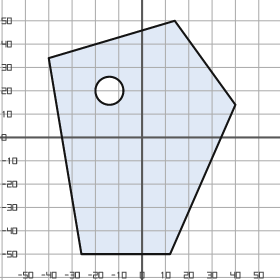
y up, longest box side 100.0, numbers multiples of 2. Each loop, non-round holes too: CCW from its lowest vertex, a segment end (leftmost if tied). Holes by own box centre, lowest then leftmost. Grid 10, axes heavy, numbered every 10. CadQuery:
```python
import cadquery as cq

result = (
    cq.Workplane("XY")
    .moveTo(-26.0, -50.0)
    .lineTo(12.0, -50.0)
    .lineTo(40.0, 14.0)
    .lineTo(14.0, 50.0)
    .lineTo(-40.0, 34.0)
    .close()
    .moveTo(-14.0, 20.0)
    .circle(6.0)
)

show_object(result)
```